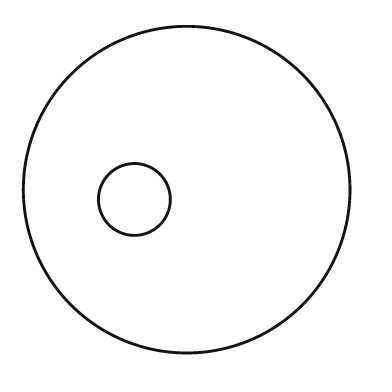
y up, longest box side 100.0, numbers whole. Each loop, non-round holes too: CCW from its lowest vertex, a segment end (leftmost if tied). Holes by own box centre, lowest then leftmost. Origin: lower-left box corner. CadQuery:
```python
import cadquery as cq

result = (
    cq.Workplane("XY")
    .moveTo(50.0, 50.0)
    .circle(50.0)
    .moveTo(34.0, 47.0)
    .circle(11.0)
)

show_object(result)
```